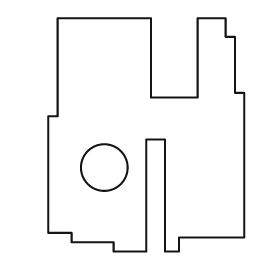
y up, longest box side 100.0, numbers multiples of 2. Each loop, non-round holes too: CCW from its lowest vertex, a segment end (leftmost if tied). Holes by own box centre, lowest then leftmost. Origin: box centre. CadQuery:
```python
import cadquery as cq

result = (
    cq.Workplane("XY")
    .moveTo(-14.0, -50.0)
    .lineTo(0.0, -50.0)
    .lineTo(0.0, -2.0)
    .lineTo(8.0, -2.0)
    .lineTo(8.0, -50.0)
    .lineTo(14.0, -50.0)
    .lineTo(14.0, -44.0)
    .lineTo(42.0, -44.0)
    .lineTo(42.0, 18.0)
    .lineTo(38.0, 18.0)
    .lineTo(38.0, 42.0)
    .lineTo(34.0, 42.0)
    .lineTo(34.0, 50.0)
    .lineTo(22.0, 50.0)
    .lineTo(22.0, 16.0)
    .lineTo(2.0, 16.0)
    .lineTo(2.0, 50.0)
    .lineTo(-38.0, 50.0)
    .lineTo(-38.0, 8.0)
    .lineTo(-42.0, 8.0)
    .lineTo(-42.0, -42.0)
    .lineTo(-32.0, -42.0)
    .lineTo(-32.0, -46.0)
    .lineTo(-14.0, -46.0)
    .close()
    .moveTo(-18.0, -14.0)
    .circle(10.0)
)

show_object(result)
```